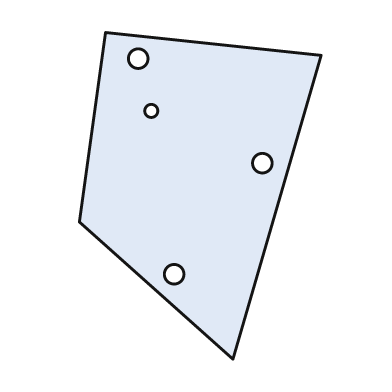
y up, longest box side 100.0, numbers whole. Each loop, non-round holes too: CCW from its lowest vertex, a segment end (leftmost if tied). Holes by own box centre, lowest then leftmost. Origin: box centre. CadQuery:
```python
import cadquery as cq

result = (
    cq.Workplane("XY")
    .moveTo(10.0, -50.0)
    .lineTo(37.0, 43.0)
    .lineTo(-29.0, 50.0)
    .lineTo(-37.0, -8.0)
    .close()
    .moveTo(-8.0, -24.0)
    .circle(3.0)
    .moveTo(19.0, 10.0)
    .circle(3.0)
    .moveTo(-15.0, 26.0)
    .circle(2.0)
    .moveTo(-19.0, 42.0)
    .circle(3.0)
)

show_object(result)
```